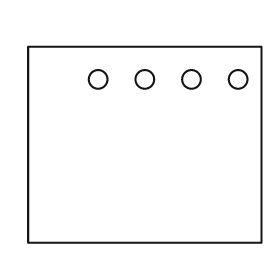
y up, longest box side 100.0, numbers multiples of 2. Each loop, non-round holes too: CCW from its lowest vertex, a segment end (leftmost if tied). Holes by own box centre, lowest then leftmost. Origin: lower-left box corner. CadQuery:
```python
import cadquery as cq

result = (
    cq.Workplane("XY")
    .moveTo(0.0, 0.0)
    .lineTo(100.0, 0.0)
    .lineTo(100.0, 84.0)
    .lineTo(0.0, 84.0)
    .close()
    .moveTo(30.0, 70.0)
    .circle(4.0)
    .moveTo(50.0, 70.0)
    .circle(4.0)
    .moveTo(70.0, 70.0)
    .circle(4.0)
    .moveTo(90.0, 70.0)
    .circle(4.0)
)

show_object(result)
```